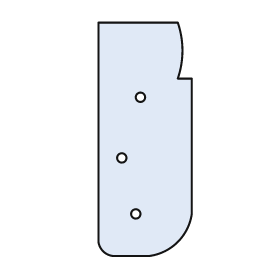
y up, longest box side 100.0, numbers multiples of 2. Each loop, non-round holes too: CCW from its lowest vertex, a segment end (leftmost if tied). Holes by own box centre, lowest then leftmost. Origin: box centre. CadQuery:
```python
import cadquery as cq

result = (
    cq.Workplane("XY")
    .moveTo(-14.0, -50.0)
    .lineTo(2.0, -50.0)
    .threePointArc((14.0, -44.0), (20.0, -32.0))
    .lineTo(20.0, 26.0)
    .lineTo(14.0, 26.0)
    .threePointArc((16.0, 38.0), (14.0, 50.0))
    .lineTo(-20.0, 50.0)
    .lineTo(-20.0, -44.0)
    .threePointArc((-18.0, -48.0), (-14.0, -50.0))
    .close()
    .moveTo(-4.0, -32.0)
    .circle(2.0)
    .moveTo(-10.0, -8.0)
    .circle(2.0)
    .moveTo(-2.0, 18.0)
    .circle(2.0)
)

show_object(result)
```